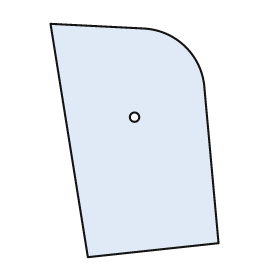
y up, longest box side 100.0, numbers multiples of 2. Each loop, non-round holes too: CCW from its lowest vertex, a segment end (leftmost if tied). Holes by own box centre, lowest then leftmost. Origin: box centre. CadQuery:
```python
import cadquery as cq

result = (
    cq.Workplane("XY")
    .moveTo(-20.0, -50.0)
    .lineTo(36.0, -44.0)
    .lineTo(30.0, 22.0)
    .threePointArc((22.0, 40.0), (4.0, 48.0))
    .lineTo(-36.0, 50.0)
    .close()
    .moveTo(0.0, 10.0)
    .circle(2.0)
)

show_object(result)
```